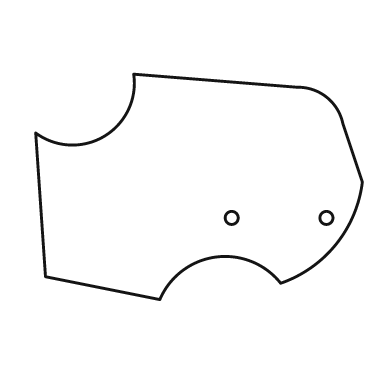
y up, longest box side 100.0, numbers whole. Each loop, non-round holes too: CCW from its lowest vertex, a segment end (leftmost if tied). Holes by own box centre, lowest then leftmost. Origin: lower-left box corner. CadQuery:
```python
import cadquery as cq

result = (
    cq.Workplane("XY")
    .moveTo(38.0, 0.0)
    .threePointArc((55.0, 13.0), (75.0, 5.0))
    .threePointArc((92.0, 17.0), (100.0, 36.0))
    .lineTo(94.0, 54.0)
    .threePointArc((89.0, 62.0), (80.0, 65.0))
    .lineTo(30.0, 69.0)
    .threePointArc((21.0, 50.0), (0.0, 51.0))
    .lineTo(3.0, 7.0)
    .close()
    .moveTo(60.0, 25.0)
    .circle(2.0)
    .moveTo(89.0, 25.0)
    .circle(2.0)
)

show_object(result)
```